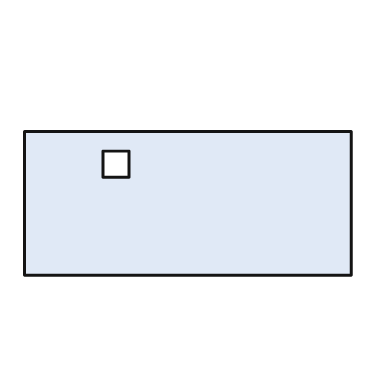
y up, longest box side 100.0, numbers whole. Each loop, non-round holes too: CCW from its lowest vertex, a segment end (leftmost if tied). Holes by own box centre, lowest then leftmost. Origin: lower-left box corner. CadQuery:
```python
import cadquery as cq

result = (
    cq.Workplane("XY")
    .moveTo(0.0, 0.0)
    .lineTo(100.0, 0.0)
    .lineTo(100.0, 44.0)
    .lineTo(0.0, 44.0)
    .close()
    .moveTo(24.0, 30.0)
    .lineTo(32.0, 30.0)
    .lineTo(32.0, 38.0)
    .lineTo(24.0, 38.0)
    .close()
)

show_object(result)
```